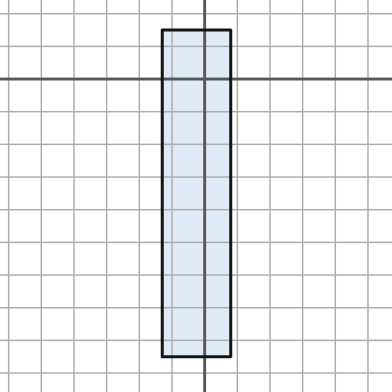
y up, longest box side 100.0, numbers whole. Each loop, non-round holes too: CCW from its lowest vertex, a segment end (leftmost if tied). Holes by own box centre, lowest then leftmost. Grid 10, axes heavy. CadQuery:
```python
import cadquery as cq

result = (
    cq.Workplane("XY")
    .moveTo(-13.0, -85.0)
    .lineTo(8.0, -85.0)
    .lineTo(8.0, 15.0)
    .lineTo(-13.0, 15.0)
    .close()
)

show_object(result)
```